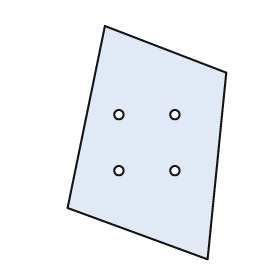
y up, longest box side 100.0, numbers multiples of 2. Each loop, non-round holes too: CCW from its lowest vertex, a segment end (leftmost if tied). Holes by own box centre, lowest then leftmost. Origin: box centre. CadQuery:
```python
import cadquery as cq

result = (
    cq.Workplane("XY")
    .moveTo(26.0, -50.0)
    .lineTo(34.0, 30.0)
    .lineTo(-18.0, 50.0)
    .lineTo(-34.0, -28.0)
    .close()
    .moveTo(-12.0, -12.0)
    .circle(2.0)
    .moveTo(12.0, -12.0)
    .circle(2.0)
    .moveTo(-12.0, 12.0)
    .circle(2.0)
    .moveTo(12.0, 12.0)
    .circle(2.0)
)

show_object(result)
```